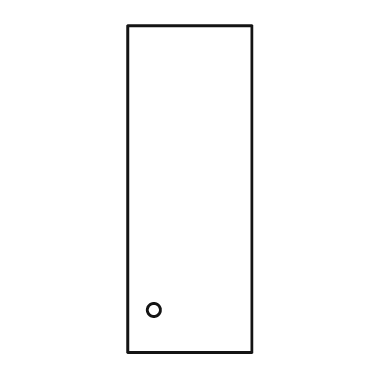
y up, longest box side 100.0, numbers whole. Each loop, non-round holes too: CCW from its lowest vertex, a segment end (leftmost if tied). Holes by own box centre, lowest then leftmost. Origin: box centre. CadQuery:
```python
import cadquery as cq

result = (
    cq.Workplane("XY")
    .moveTo(-19.0, -50.0)
    .lineTo(19.0, -50.0)
    .lineTo(19.0, 50.0)
    .lineTo(-19.0, 50.0)
    .close()
    .moveTo(-11.0, -37.0)
    .circle(2.0)
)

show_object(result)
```